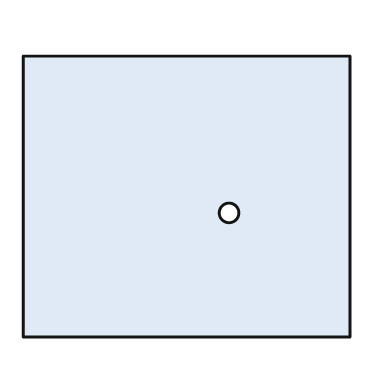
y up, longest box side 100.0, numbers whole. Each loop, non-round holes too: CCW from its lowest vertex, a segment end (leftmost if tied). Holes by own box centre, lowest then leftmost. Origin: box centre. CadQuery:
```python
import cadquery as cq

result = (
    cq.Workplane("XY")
    .moveTo(-50.0, -43.0)
    .lineTo(50.0, -43.0)
    .lineTo(50.0, 43.0)
    .lineTo(-50.0, 43.0)
    .close()
    .moveTo(13.0, -5.0)
    .circle(3.0)
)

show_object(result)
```